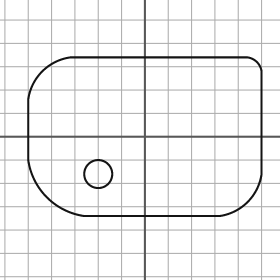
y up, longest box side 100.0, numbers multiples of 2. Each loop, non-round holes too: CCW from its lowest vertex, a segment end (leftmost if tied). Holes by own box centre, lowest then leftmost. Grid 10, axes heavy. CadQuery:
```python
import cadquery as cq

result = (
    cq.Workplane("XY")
    .moveTo(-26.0, -34.0)
    .lineTo(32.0, -34.0)
    .threePointArc((44.0, -28.0), (50.0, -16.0))
    .lineTo(50.0, 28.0)
    .threePointArc((48.0, 32.0), (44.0, 34.0))
    .lineTo(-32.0, 34.0)
    .threePointArc((-44.0, 28.0), (-50.0, 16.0))
    .lineTo(-50.0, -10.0)
    .threePointArc((-42.0, -26.0), (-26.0, -34.0))
    .close()
    .moveTo(-20.0, -16.0)
    .circle(6.0)
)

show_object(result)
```